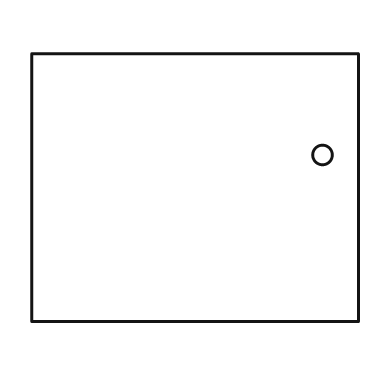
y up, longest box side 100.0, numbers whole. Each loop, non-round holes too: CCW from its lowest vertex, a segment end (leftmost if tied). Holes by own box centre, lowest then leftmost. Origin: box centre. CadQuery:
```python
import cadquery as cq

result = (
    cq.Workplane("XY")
    .moveTo(-50.0, -41.0)
    .lineTo(50.0, -41.0)
    .lineTo(50.0, 41.0)
    .lineTo(-50.0, 41.0)
    .close()
    .moveTo(39.0, 10.0)
    .circle(3.0)
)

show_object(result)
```